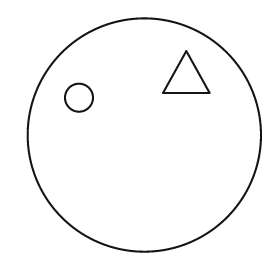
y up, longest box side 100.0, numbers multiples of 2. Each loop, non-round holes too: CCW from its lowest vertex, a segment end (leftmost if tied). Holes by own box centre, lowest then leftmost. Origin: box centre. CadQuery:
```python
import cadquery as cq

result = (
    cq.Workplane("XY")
    .moveTo(0.0, 0.0)
    .circle(50.0)
    .moveTo(-28.0, 16.0)
    .circle(6.0)
    .moveTo(8.0, 18.0)
    .lineTo(28.0, 18.0)
    .lineTo(18.0, 36.0)
    .close()
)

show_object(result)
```